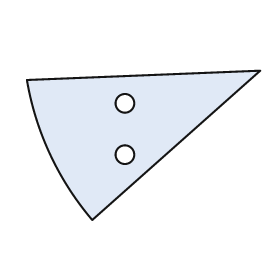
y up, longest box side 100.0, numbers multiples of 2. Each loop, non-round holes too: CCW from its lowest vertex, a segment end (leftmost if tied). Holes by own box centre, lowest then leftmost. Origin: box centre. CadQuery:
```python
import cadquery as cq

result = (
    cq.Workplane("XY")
    .moveTo(-22.0, -32.0)
    .lineTo(50.0, 32.0)
    .lineTo(-50.0, 28.0)
    .threePointArc((-40.0, -4.0), (-22.0, -32.0))
    .close()
    .moveTo(-8.0, -4.0)
    .circle(4.0)
    .moveTo(-8.0, 18.0)
    .circle(4.0)
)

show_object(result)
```